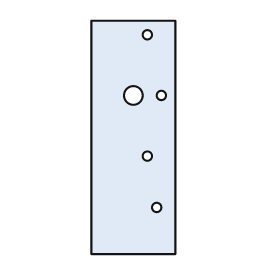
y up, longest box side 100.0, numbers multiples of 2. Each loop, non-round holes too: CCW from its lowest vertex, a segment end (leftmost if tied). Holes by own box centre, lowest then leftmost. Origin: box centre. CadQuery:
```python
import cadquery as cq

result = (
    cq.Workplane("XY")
    .moveTo(-18.0, -50.0)
    .lineTo(18.0, -50.0)
    .lineTo(18.0, 50.0)
    .lineTo(-18.0, 50.0)
    .close()
    .moveTo(10.0, -30.0)
    .circle(2.0)
    .moveTo(6.0, -8.0)
    .circle(2.0)
    .moveTo(0.0, 18.0)
    .circle(4.0)
    .moveTo(12.0, 18.0)
    .circle(2.0)
    .moveTo(6.0, 44.0)
    .circle(2.0)
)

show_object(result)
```